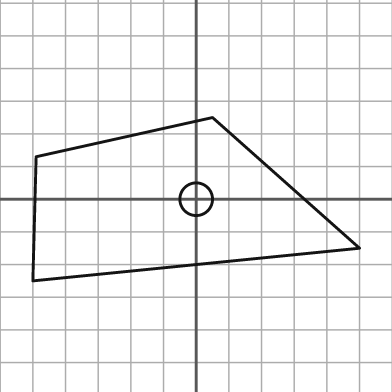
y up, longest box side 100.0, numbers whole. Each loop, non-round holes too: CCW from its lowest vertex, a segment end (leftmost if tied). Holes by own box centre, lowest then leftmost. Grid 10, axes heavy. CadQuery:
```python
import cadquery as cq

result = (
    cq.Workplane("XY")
    .moveTo(-50.0, -25.0)
    .lineTo(50.0, -15.0)
    .lineTo(5.0, 25.0)
    .lineTo(-49.0, 13.0)
    .close()
    .moveTo(0.0, 0.0)
    .circle(5.0)
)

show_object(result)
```